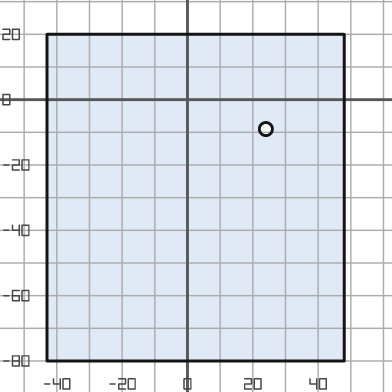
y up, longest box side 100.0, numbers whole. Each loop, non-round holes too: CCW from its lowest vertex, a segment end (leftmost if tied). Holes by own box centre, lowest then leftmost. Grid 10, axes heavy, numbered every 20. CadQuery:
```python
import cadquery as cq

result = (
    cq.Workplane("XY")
    .moveTo(-43.0, -80.0)
    .lineTo(48.0, -80.0)
    .lineTo(48.0, 20.0)
    .lineTo(-43.0, 20.0)
    .close()
    .moveTo(24.0, -9.0)
    .circle(2.0)
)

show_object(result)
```